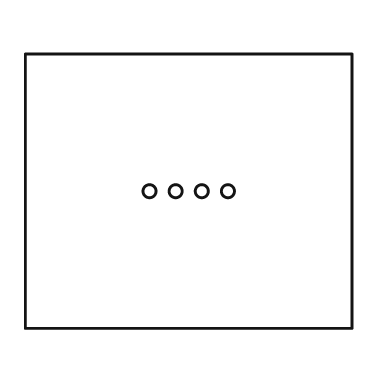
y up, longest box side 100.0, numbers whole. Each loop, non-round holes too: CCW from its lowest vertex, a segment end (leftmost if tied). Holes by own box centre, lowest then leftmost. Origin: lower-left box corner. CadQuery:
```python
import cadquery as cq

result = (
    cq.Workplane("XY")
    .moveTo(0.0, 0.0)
    .lineTo(100.0, 0.0)
    .lineTo(100.0, 84.0)
    .lineTo(0.0, 84.0)
    .close()
    .moveTo(38.0, 42.0)
    .circle(2.0)
    .moveTo(46.0, 42.0)
    .circle(2.0)
    .moveTo(54.0, 42.0)
    .circle(2.0)
    .moveTo(62.0, 42.0)
    .circle(2.0)
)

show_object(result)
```